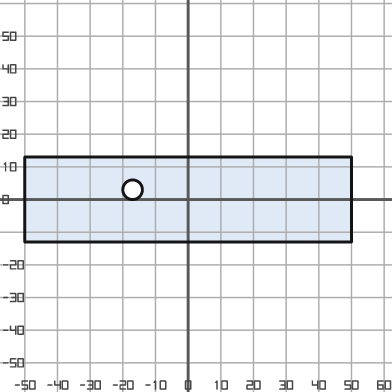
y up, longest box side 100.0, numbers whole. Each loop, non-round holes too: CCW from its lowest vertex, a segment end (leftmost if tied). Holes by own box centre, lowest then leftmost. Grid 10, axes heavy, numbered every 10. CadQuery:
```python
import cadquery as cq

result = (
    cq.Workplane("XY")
    .moveTo(-50.0, -13.0)
    .lineTo(50.0, -13.0)
    .lineTo(50.0, 13.0)
    .lineTo(-50.0, 13.0)
    .close()
    .moveTo(-17.0, 3.0)
    .circle(3.0)
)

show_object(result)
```